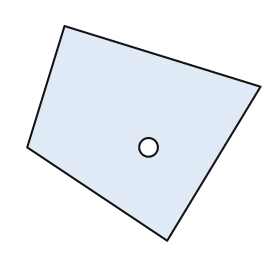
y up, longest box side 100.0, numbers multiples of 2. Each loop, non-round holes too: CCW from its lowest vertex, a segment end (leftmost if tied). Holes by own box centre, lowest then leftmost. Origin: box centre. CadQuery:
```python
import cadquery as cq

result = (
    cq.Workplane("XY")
    .moveTo(10.0, -46.0)
    .lineTo(50.0, 20.0)
    .lineTo(-34.0, 46.0)
    .lineTo(-50.0, -6.0)
    .close()
    .moveTo(2.0, -6.0)
    .circle(4.0)
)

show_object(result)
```